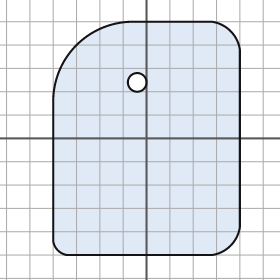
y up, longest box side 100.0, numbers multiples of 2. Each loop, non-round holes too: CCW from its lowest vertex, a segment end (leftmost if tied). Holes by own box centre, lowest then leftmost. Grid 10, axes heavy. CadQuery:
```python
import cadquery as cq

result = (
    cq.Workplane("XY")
    .moveTo(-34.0, -50.0)
    .lineTo(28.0, -50.0)
    .threePointArc((36.0, -46.0), (40.0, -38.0))
    .lineTo(40.0, 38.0)
    .threePointArc((36.0, 46.0), (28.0, 50.0))
    .lineTo(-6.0, 50.0)
    .threePointArc((-30.0, 40.0), (-40.0, 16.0))
    .lineTo(-40.0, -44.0)
    .threePointArc((-38.0, -48.0), (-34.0, -50.0))
    .close()
    .moveTo(-4.0, 24.0)
    .circle(4.0)
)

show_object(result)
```